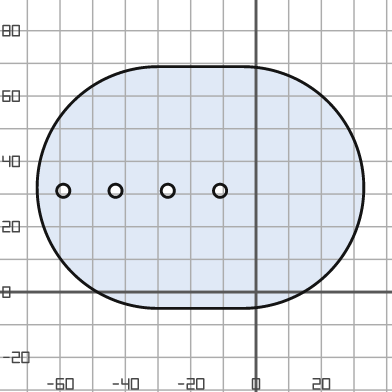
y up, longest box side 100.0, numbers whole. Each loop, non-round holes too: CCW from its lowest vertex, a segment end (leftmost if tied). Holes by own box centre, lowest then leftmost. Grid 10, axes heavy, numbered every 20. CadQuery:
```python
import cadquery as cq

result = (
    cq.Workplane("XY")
    .moveTo(-30.0, -5.0)
    .lineTo(-4.0, -5.0)
    .threePointArc((33.0, 32.0), (-4.0, 69.0))
    .lineTo(-30.0, 69.0)
    .threePointArc((-67.0, 32.0), (-30.0, -5.0))
    .close()
    .moveTo(-59.0, 31.0)
    .circle(2.0)
    .moveTo(-43.0, 31.0)
    .circle(2.0)
    .moveTo(-27.0, 31.0)
    .circle(2.0)
    .moveTo(-11.0, 31.0)
    .circle(2.0)
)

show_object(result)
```